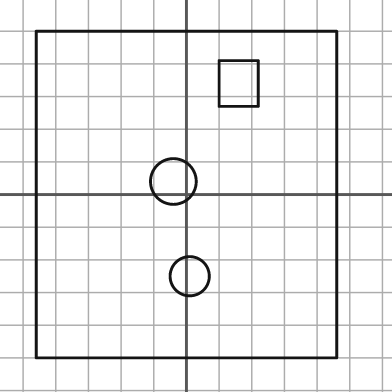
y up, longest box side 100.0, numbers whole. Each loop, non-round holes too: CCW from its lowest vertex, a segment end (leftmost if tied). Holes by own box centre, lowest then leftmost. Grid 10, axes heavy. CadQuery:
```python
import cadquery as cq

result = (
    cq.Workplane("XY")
    .moveTo(-46.0, -50.0)
    .lineTo(46.0, -50.0)
    .lineTo(46.0, 50.0)
    .lineTo(-46.0, 50.0)
    .close()
    .moveTo(1.0, -25.0)
    .circle(6.0)
    .moveTo(-4.0, 4.0)
    .circle(7.0)
    .moveTo(10.0, 27.0)
    .lineTo(22.0, 27.0)
    .lineTo(22.0, 41.0)
    .lineTo(10.0, 41.0)
    .close()
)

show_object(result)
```